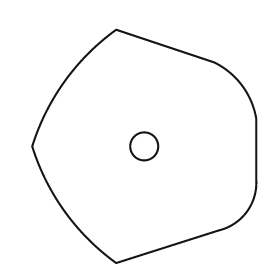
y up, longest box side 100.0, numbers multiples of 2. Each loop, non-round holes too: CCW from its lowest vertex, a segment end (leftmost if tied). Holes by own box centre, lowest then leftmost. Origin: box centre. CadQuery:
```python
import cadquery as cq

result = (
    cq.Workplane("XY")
    .moveTo(-12.0, -50.0)
    .lineTo(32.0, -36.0)
    .threePointArc((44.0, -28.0), (48.0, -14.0))
    .lineTo(48.0, 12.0)
    .threePointArc((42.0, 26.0), (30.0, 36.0))
    .lineTo(-12.0, 50.0)
    .threePointArc((-34.0, 28.0), (-48.0, 0.0))
    .threePointArc((-34.0, -28.0), (-12.0, -50.0))
    .close()
    .moveTo(0.0, 0.0)
    .circle(6.0)
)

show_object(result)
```